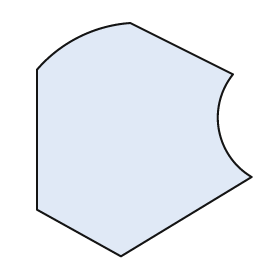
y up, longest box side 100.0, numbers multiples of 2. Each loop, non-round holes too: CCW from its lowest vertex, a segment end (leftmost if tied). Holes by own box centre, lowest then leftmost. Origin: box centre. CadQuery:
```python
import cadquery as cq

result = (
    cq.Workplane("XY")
    .moveTo(-10.0, -50.0)
    .lineTo(46.0, -16.0)
    .threePointArc((32.0, 4.0), (38.0, 28.0))
    .lineTo(-6.0, 50.0)
    .threePointArc((-28.0, 44.0), (-46.0, 30.0))
    .lineTo(-46.0, -30.0)
    .close()
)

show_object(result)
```